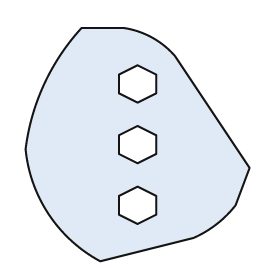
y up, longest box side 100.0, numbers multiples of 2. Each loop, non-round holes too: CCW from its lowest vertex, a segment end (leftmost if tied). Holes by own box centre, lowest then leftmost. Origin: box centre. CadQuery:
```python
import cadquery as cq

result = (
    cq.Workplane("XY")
    .moveTo(-16.0, -50.0)
    .lineTo(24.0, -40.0)
    .threePointArc((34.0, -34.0), (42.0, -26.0))
    .lineTo(48.0, -10.0)
    .lineTo(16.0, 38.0)
    .threePointArc((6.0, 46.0), (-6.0, 50.0))
    .lineTo(-24.0, 50.0)
    .threePointArc((-40.0, 26.0), (-48.0, -2.0))
    .threePointArc((-38.0, -30.0), (-16.0, -50.0))
    .close()
    .moveTo(0.0, -34.0)
    .lineTo(8.0, -30.0)
    .lineTo(8.0, -22.0)
    .lineTo(0.0, -18.0)
    .lineTo(-8.0, -22.0)
    .lineTo(-8.0, -30.0)
    .close()
    .moveTo(0.0, -8.0)
    .lineTo(8.0, -4.0)
    .lineTo(8.0, 4.0)
    .lineTo(0.0, 8.0)
    .lineTo(-8.0, 4.0)
    .lineTo(-8.0, -4.0)
    .close()
    .moveTo(0.0, 18.0)
    .lineTo(8.0, 22.0)
    .lineTo(8.0, 30.0)
    .lineTo(0.0, 34.0)
    .lineTo(-8.0, 30.0)
    .lineTo(-8.0, 22.0)
    .close()
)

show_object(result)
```